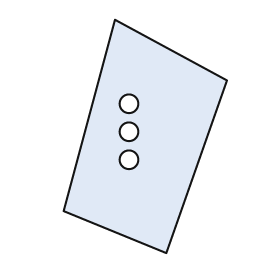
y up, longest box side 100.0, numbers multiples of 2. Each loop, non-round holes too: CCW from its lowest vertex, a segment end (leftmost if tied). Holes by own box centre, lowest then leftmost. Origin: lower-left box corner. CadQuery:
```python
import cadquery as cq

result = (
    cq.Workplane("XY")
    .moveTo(44.0, 0.0)
    .lineTo(70.0, 74.0)
    .lineTo(22.0, 100.0)
    .lineTo(0.0, 18.0)
    .close()
    .moveTo(28.0, 40.0)
    .circle(4.0)
    .moveTo(28.0, 52.0)
    .circle(4.0)
    .moveTo(28.0, 64.0)
    .circle(4.0)
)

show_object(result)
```